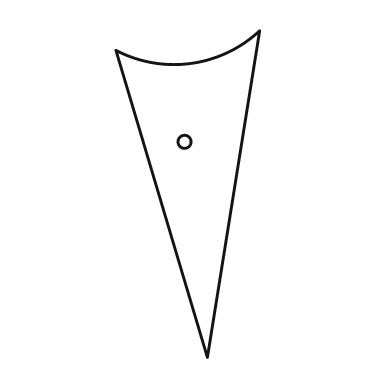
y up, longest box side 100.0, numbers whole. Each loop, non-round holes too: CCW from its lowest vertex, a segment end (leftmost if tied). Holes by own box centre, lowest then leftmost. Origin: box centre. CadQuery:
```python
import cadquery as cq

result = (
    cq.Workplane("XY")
    .moveTo(6.0, -50.0)
    .lineTo(22.0, 50.0)
    .threePointArc((1.0, 40.0), (-22.0, 44.0))
    .close()
    .moveTo(-1.0, 16.0)
    .circle(2.0)
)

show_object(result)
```